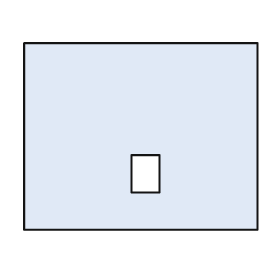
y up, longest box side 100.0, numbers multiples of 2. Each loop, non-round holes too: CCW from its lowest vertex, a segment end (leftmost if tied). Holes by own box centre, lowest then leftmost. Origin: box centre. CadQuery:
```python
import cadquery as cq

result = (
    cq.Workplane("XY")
    .moveTo(-50.0, -40.0)
    .lineTo(50.0, -40.0)
    .lineTo(50.0, 40.0)
    .lineTo(-50.0, 40.0)
    .close()
    .moveTo(-4.0, -24.0)
    .lineTo(8.0, -24.0)
    .lineTo(8.0, -8.0)
    .lineTo(-4.0, -8.0)
    .close()
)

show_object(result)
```